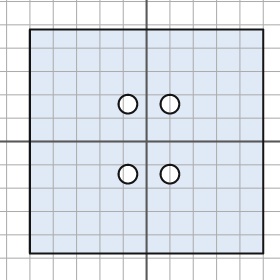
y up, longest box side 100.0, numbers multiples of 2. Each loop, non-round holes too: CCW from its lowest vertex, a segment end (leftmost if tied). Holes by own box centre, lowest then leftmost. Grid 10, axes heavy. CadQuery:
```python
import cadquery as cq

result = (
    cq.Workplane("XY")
    .moveTo(-50.0, -48.0)
    .lineTo(50.0, -48.0)
    .lineTo(50.0, 48.0)
    .lineTo(-50.0, 48.0)
    .close()
    .moveTo(-8.0, -14.0)
    .circle(4.0)
    .moveTo(10.0, -14.0)
    .circle(4.0)
    .moveTo(-8.0, 16.0)
    .circle(4.0)
    .moveTo(10.0, 16.0)
    .circle(4.0)
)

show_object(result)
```